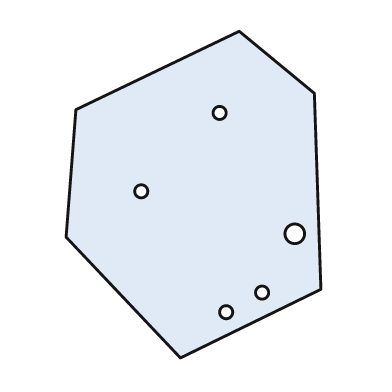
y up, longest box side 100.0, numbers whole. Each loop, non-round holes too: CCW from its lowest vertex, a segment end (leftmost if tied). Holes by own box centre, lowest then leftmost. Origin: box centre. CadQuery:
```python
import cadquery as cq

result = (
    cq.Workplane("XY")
    .moveTo(-4.0, -50.0)
    .lineTo(39.0, -29.0)
    .lineTo(37.0, 31.0)
    .lineTo(14.0, 50.0)
    .lineTo(-36.0, 26.0)
    .lineTo(-39.0, -13.0)
    .close()
    .moveTo(10.0, -36.0)
    .circle(2.0)
    .moveTo(21.0, -30.0)
    .circle(2.0)
    .moveTo(31.0, -12.0)
    .circle(3.0)
    .moveTo(-16.0, 1.0)
    .circle(2.0)
    .moveTo(8.0, 25.0)
    .circle(2.0)
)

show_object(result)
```